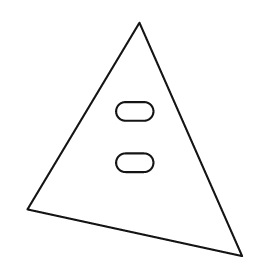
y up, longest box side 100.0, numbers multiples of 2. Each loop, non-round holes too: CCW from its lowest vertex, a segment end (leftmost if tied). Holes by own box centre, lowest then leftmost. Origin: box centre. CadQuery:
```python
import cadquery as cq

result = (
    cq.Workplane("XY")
    .moveTo(46.0, -50.0)
    .lineTo(2.0, 50.0)
    .lineTo(-46.0, -30.0)
    .close()
    .moveTo(-4.0, -14.0)
    .lineTo(4.0, -14.0)
    .threePointArc((8.0, -10.0), (4.0, -6.0))
    .lineTo(-4.0, -6.0)
    .threePointArc((-8.0, -10.0), (-4.0, -14.0))
    .close()
    .moveTo(-4.0, 8.0)
    .lineTo(4.0, 8.0)
    .threePointArc((8.0, 12.0), (4.0, 16.0))
    .lineTo(-4.0, 16.0)
    .threePointArc((-8.0, 12.0), (-4.0, 8.0))
    .close()
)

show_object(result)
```